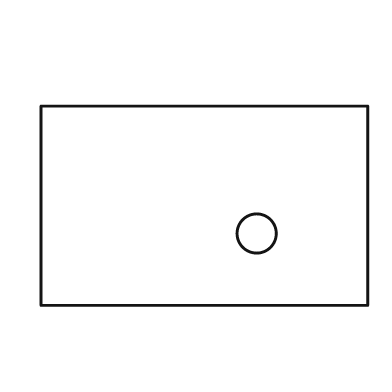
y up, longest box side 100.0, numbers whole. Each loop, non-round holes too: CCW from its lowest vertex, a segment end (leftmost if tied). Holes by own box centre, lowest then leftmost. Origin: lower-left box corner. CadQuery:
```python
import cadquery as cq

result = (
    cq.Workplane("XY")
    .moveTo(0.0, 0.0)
    .lineTo(100.0, 0.0)
    .lineTo(100.0, 61.0)
    .lineTo(0.0, 61.0)
    .close()
    .moveTo(66.0, 22.0)
    .circle(6.0)
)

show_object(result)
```